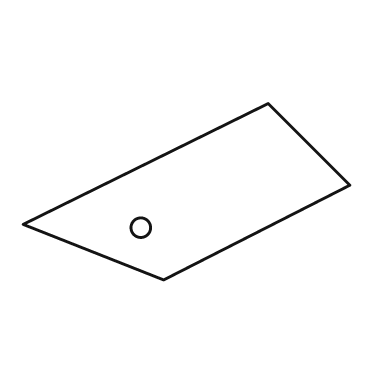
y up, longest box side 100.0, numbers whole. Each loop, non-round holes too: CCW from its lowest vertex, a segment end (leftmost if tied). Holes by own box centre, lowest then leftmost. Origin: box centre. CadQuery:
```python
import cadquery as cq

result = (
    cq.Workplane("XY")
    .moveTo(-7.0, -27.0)
    .lineTo(50.0, 2.0)
    .lineTo(25.0, 27.0)
    .lineTo(-50.0, -10.0)
    .close()
    .moveTo(-14.0, -11.0)
    .circle(3.0)
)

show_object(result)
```